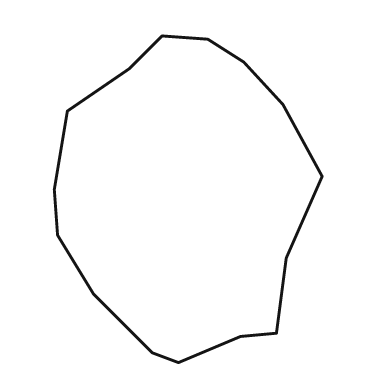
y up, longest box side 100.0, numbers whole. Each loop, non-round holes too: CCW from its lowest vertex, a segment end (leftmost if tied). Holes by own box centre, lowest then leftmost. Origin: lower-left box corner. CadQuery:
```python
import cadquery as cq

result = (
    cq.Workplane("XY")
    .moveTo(38.0, 0.0)
    .lineTo(57.0, 8.0)
    .lineTo(68.0, 9.0)
    .lineTo(71.0, 32.0)
    .lineTo(82.0, 57.0)
    .lineTo(70.0, 79.0)
    .lineTo(58.0, 92.0)
    .lineTo(47.0, 99.0)
    .lineTo(33.0, 100.0)
    .lineTo(23.0, 90.0)
    .lineTo(4.0, 77.0)
    .lineTo(0.0, 53.0)
    .lineTo(1.0, 39.0)
    .lineTo(12.0, 21.0)
    .lineTo(30.0, 3.0)
    .close()
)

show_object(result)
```